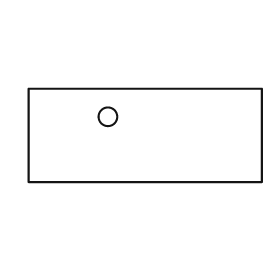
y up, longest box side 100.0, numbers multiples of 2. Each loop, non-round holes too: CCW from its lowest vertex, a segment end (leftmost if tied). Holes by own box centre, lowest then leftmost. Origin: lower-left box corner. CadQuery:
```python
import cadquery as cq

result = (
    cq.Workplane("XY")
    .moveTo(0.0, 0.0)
    .lineTo(100.0, 0.0)
    .lineTo(100.0, 40.0)
    .lineTo(0.0, 40.0)
    .close()
    .moveTo(34.0, 28.0)
    .circle(4.0)
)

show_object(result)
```